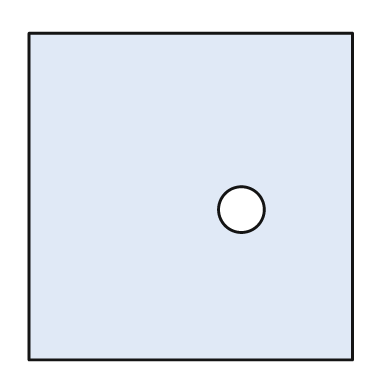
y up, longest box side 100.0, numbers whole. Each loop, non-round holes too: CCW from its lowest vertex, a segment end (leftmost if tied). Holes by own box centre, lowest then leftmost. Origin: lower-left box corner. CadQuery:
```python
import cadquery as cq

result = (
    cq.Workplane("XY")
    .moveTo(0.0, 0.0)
    .lineTo(99.0, 0.0)
    .lineTo(99.0, 100.0)
    .lineTo(0.0, 100.0)
    .close()
    .moveTo(65.0, 46.0)
    .circle(7.0)
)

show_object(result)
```